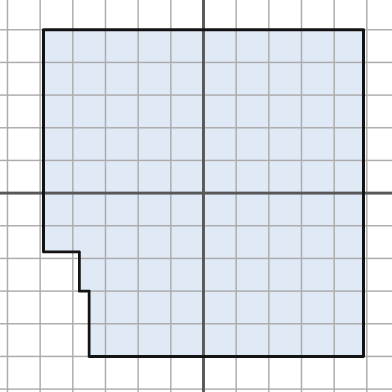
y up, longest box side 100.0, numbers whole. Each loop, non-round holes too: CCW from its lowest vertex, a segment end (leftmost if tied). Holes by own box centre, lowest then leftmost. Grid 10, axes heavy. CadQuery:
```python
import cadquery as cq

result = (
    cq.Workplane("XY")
    .moveTo(-35.0, -50.0)
    .lineTo(49.0, -50.0)
    .lineTo(49.0, 50.0)
    .lineTo(-49.0, 50.0)
    .lineTo(-49.0, -18.0)
    .lineTo(-38.0, -18.0)
    .lineTo(-38.0, -30.0)
    .lineTo(-35.0, -30.0)
    .close()
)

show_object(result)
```